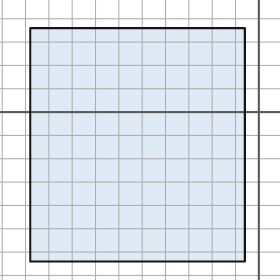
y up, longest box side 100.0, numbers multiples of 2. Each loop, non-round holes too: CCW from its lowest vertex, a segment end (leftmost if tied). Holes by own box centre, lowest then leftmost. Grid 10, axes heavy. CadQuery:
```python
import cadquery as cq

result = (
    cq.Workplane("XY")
    .moveTo(-98.0, -64.0)
    .lineTo(-6.0, -64.0)
    .lineTo(-6.0, 36.0)
    .lineTo(-98.0, 36.0)
    .close()
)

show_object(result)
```